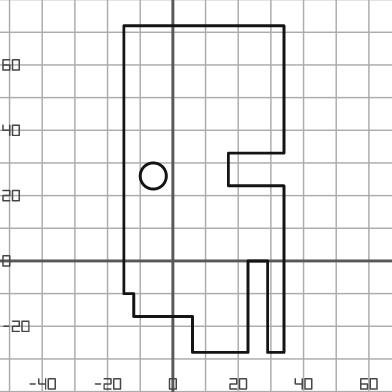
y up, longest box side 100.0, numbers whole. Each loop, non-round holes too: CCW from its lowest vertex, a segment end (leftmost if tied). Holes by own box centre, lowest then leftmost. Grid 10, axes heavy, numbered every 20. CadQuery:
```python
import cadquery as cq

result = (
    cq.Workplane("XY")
    .moveTo(6.0, -28.0)
    .lineTo(23.0, -28.0)
    .lineTo(23.0, 0.0)
    .lineTo(29.0, 0.0)
    .lineTo(29.0, -28.0)
    .lineTo(34.0, -28.0)
    .lineTo(34.0, 23.0)
    .lineTo(17.0, 23.0)
    .lineTo(17.0, 33.0)
    .lineTo(34.0, 33.0)
    .lineTo(34.0, 72.0)
    .lineTo(-15.0, 72.0)
    .lineTo(-15.0, -10.0)
    .lineTo(-12.0, -10.0)
    .lineTo(-12.0, -17.0)
    .lineTo(6.0, -17.0)
    .close()
    .moveTo(-6.0, 26.0)
    .circle(4.0)
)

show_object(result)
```